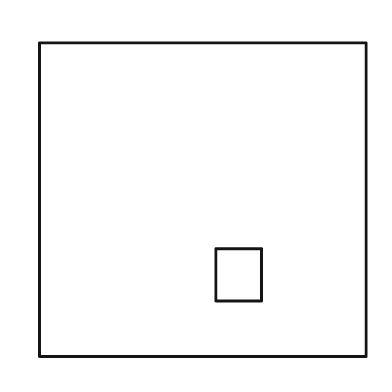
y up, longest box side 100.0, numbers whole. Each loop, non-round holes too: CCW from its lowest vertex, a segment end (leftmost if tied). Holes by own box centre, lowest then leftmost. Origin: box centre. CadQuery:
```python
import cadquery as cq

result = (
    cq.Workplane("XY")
    .moveTo(-50.0, -48.0)
    .lineTo(50.0, -48.0)
    .lineTo(50.0, 48.0)
    .lineTo(-50.0, 48.0)
    .close()
    .moveTo(4.0, -31.0)
    .lineTo(18.0, -31.0)
    .lineTo(18.0, -15.0)
    .lineTo(4.0, -15.0)
    .close()
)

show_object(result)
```